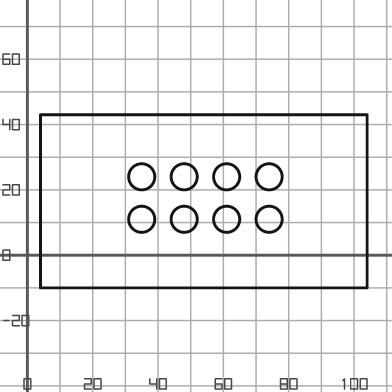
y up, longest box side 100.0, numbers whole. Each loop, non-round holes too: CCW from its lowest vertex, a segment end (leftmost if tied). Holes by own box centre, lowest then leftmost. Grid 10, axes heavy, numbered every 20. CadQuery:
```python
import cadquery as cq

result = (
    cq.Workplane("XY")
    .moveTo(4.0, -10.0)
    .lineTo(104.0, -10.0)
    .lineTo(104.0, 43.0)
    .lineTo(4.0, 43.0)
    .close()
    .moveTo(35.0, 11.0)
    .circle(4.0)
    .moveTo(48.0, 11.0)
    .circle(4.0)
    .moveTo(61.0, 11.0)
    .circle(4.0)
    .moveTo(74.0, 11.0)
    .circle(4.0)
    .moveTo(35.0, 24.0)
    .circle(4.0)
    .moveTo(48.0, 24.0)
    .circle(4.0)
    .moveTo(61.0, 24.0)
    .circle(4.0)
    .moveTo(74.0, 24.0)
    .circle(4.0)
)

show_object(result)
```